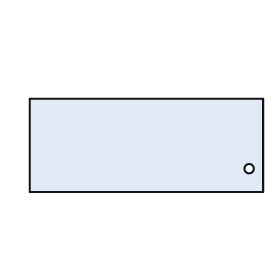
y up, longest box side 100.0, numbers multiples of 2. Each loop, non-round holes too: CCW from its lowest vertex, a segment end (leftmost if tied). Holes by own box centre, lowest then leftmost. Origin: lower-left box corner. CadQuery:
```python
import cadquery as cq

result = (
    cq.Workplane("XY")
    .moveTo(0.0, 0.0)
    .lineTo(100.0, 0.0)
    .lineTo(100.0, 40.0)
    .lineTo(0.0, 40.0)
    .close()
    .moveTo(94.0, 10.0)
    .circle(2.0)
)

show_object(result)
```